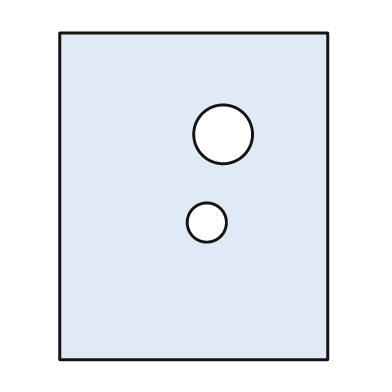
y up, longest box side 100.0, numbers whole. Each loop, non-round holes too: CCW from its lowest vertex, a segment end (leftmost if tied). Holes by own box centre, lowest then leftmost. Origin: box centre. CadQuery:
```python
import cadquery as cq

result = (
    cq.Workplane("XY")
    .moveTo(-41.0, -50.0)
    .lineTo(41.0, -50.0)
    .lineTo(41.0, 50.0)
    .lineTo(-41.0, 50.0)
    .close()
    .moveTo(4.0, -8.0)
    .circle(6.0)
    .moveTo(9.0, 19.0)
    .circle(9.0)
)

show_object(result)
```